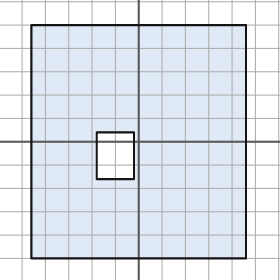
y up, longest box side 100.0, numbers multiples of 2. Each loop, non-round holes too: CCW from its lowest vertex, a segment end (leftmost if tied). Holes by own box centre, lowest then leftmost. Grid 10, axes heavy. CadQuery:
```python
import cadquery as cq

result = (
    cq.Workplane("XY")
    .moveTo(-46.0, -50.0)
    .lineTo(46.0, -50.0)
    .lineTo(46.0, 50.0)
    .lineTo(-46.0, 50.0)
    .close()
    .moveTo(-18.0, -16.0)
    .lineTo(-2.0, -16.0)
    .lineTo(-2.0, 4.0)
    .lineTo(-18.0, 4.0)
    .close()
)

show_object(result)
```